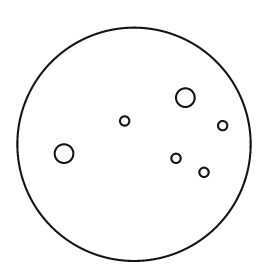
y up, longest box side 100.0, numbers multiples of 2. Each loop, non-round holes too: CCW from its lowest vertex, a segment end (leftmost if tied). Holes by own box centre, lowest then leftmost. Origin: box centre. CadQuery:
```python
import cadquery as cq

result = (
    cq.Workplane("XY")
    .moveTo(0.0, 0.0)
    .circle(50.0)
    .moveTo(30.0, -12.0)
    .circle(2.0)
    .moveTo(18.0, -6.0)
    .circle(2.0)
    .moveTo(-30.0, -4.0)
    .circle(4.0)
    .moveTo(38.0, 8.0)
    .circle(2.0)
    .moveTo(-4.0, 10.0)
    .circle(2.0)
    .moveTo(22.0, 20.0)
    .circle(4.0)
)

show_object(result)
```